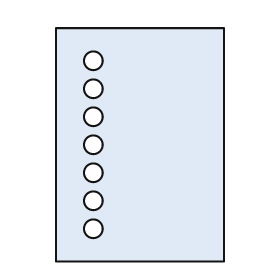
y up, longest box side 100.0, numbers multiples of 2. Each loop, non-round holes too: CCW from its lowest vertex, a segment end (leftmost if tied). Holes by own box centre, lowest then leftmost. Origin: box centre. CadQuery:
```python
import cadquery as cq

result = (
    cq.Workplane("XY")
    .moveTo(-36.0, -50.0)
    .lineTo(36.0, -50.0)
    .lineTo(36.0, 50.0)
    .lineTo(-36.0, 50.0)
    .close()
    .moveTo(-20.0, -36.0)
    .circle(4.0)
    .moveTo(-20.0, -24.0)
    .circle(4.0)
    .moveTo(-20.0, -12.0)
    .circle(4.0)
    .moveTo(-20.0, 0.0)
    .circle(4.0)
    .moveTo(-20.0, 12.0)
    .circle(4.0)
    .moveTo(-20.0, 24.0)
    .circle(4.0)
    .moveTo(-20.0, 36.0)
    .circle(4.0)
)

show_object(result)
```